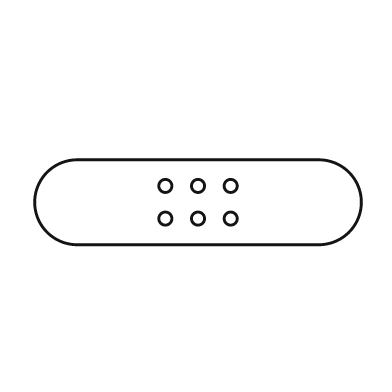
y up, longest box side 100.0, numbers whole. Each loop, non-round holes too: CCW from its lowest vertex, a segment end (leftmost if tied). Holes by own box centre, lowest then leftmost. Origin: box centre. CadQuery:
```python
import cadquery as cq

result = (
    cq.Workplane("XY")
    .moveTo(-37.0, -13.0)
    .lineTo(37.0, -13.0)
    .threePointArc((50.0, 0.0), (37.0, 13.0))
    .lineTo(-37.0, 13.0)
    .threePointArc((-50.0, 0.0), (-37.0, -13.0))
    .close()
    .moveTo(-10.0, -5.0)
    .circle(2.0)
    .moveTo(0.0, -5.0)
    .circle(2.0)
    .moveTo(10.0, -5.0)
    .circle(2.0)
    .moveTo(-10.0, 5.0)
    .circle(2.0)
    .moveTo(0.0, 5.0)
    .circle(2.0)
    .moveTo(10.0, 5.0)
    .circle(2.0)
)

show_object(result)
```